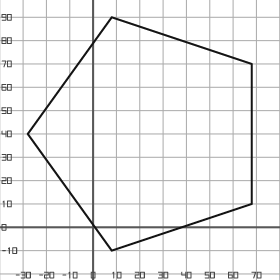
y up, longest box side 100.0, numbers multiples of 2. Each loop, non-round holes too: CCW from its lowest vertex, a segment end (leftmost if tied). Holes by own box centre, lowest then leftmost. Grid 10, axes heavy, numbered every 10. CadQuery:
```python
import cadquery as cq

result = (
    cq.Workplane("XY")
    .moveTo(8.0, -10.0)
    .lineTo(68.0, 10.0)
    .lineTo(68.0, 70.0)
    .lineTo(8.0, 90.0)
    .lineTo(-28.0, 40.0)
    .close()
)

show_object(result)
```